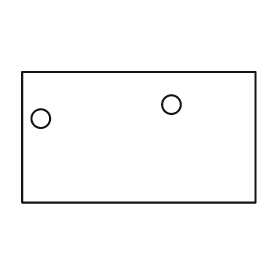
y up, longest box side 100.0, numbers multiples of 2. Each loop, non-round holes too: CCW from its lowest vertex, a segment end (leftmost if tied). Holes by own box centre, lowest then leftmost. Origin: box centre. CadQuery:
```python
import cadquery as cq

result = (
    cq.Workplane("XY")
    .moveTo(-50.0, -28.0)
    .lineTo(50.0, -28.0)
    .lineTo(50.0, 28.0)
    .lineTo(-50.0, 28.0)
    .close()
    .moveTo(-42.0, 8.0)
    .circle(4.0)
    .moveTo(14.0, 14.0)
    .circle(4.0)
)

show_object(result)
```